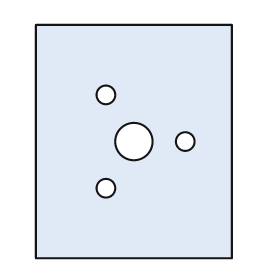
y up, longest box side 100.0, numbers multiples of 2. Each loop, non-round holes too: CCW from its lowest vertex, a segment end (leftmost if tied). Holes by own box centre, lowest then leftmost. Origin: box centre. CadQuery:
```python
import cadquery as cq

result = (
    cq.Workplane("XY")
    .moveTo(-42.0, -50.0)
    .lineTo(42.0, -50.0)
    .lineTo(42.0, 50.0)
    .lineTo(-42.0, 50.0)
    .close()
    .moveTo(-12.0, -20.0)
    .circle(4.0)
    .moveTo(0.0, 0.0)
    .circle(8.0)
    .moveTo(22.0, 0.0)
    .circle(4.0)
    .moveTo(-12.0, 20.0)
    .circle(4.0)
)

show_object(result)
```